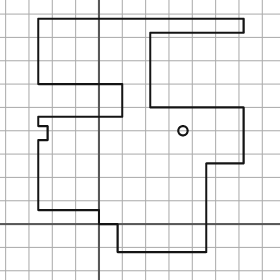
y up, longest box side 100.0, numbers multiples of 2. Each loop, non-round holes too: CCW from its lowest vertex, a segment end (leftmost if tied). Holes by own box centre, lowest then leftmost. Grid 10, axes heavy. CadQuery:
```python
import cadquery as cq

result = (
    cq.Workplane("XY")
    .moveTo(8.0, -12.0)
    .lineTo(46.0, -12.0)
    .lineTo(46.0, 26.0)
    .lineTo(62.0, 26.0)
    .lineTo(62.0, 50.0)
    .lineTo(22.0, 50.0)
    .lineTo(22.0, 82.0)
    .lineTo(62.0, 82.0)
    .lineTo(62.0, 88.0)
    .lineTo(-26.0, 88.0)
    .lineTo(-26.0, 60.0)
    .lineTo(10.0, 60.0)
    .lineTo(10.0, 46.0)
    .lineTo(-26.0, 46.0)
    .lineTo(-26.0, 42.0)
    .lineTo(-22.0, 42.0)
    .lineTo(-22.0, 36.0)
    .lineTo(-26.0, 36.0)
    .lineTo(-26.0, 6.0)
    .lineTo(0.0, 6.0)
    .lineTo(0.0, 0.0)
    .lineTo(8.0, 0.0)
    .close()
    .moveTo(36.0, 40.0)
    .circle(2.0)
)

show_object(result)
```